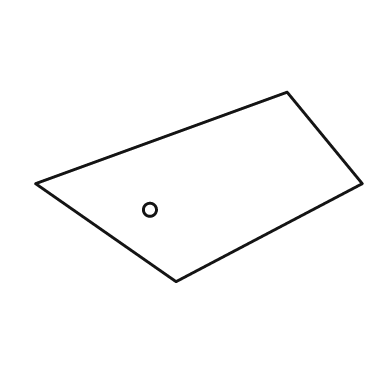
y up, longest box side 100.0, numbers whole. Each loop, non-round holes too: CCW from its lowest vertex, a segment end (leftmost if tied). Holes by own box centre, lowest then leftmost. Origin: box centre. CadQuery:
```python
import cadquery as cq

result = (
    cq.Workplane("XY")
    .moveTo(-7.0, -29.0)
    .lineTo(50.0, 1.0)
    .lineTo(27.0, 29.0)
    .lineTo(-50.0, 1.0)
    .close()
    .moveTo(-15.0, -7.0)
    .circle(2.0)
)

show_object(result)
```